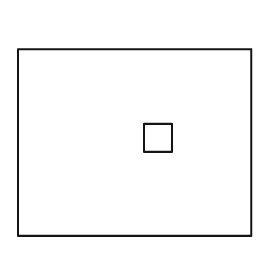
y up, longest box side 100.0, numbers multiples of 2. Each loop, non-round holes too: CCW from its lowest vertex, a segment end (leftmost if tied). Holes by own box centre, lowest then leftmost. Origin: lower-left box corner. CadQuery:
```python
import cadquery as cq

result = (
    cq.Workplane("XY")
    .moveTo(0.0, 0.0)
    .lineTo(100.0, 0.0)
    .lineTo(100.0, 80.0)
    .lineTo(0.0, 80.0)
    .close()
    .moveTo(54.0, 36.0)
    .lineTo(66.0, 36.0)
    .lineTo(66.0, 48.0)
    .lineTo(54.0, 48.0)
    .close()
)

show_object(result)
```